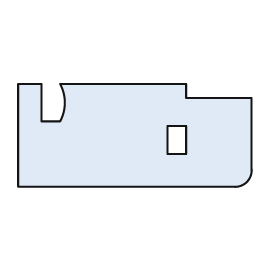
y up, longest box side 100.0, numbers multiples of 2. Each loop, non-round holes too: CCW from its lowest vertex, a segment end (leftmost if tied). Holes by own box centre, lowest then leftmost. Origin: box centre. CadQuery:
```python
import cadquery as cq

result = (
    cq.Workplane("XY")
    .moveTo(-50.0, -22.0)
    .lineTo(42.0, -22.0)
    .threePointArc((48.0, -20.0), (50.0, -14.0))
    .lineTo(50.0, 16.0)
    .lineTo(22.0, 16.0)
    .lineTo(22.0, 22.0)
    .lineTo(-32.0, 22.0)
    .threePointArc((-30.0, 14.0), (-32.0, 6.0))
    .lineTo(-40.0, 6.0)
    .lineTo(-40.0, 22.0)
    .lineTo(-50.0, 22.0)
    .close()
    .moveTo(14.0, -8.0)
    .lineTo(22.0, -8.0)
    .lineTo(22.0, 4.0)
    .lineTo(14.0, 4.0)
    .close()
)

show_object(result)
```